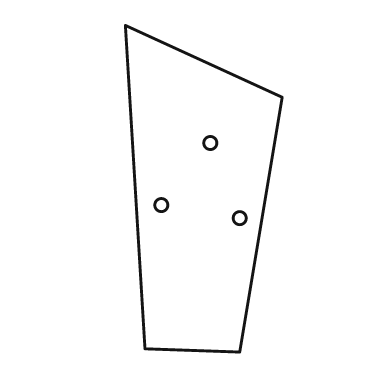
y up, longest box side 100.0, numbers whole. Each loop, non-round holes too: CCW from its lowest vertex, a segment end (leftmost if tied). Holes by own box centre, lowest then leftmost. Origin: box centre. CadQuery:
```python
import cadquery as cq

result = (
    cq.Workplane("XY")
    .moveTo(11.0, -50.0)
    .lineTo(24.0, 28.0)
    .lineTo(-24.0, 50.0)
    .lineTo(-18.0, -49.0)
    .close()
    .moveTo(11.0, -9.0)
    .circle(2.0)
    .moveTo(-13.0, -5.0)
    .circle(2.0)
    .moveTo(2.0, 14.0)
    .circle(2.0)
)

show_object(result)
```